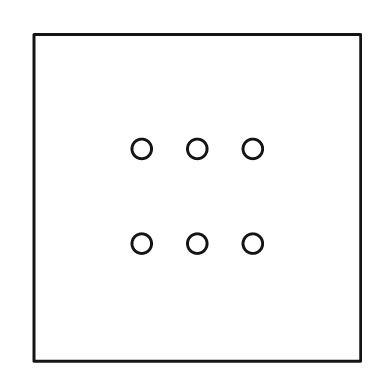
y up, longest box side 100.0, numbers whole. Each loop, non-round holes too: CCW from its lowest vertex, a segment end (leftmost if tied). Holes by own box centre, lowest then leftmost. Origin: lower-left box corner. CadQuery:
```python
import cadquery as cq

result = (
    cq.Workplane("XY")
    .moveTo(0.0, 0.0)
    .lineTo(100.0, 0.0)
    .lineTo(100.0, 100.0)
    .lineTo(0.0, 100.0)
    .close()
    .moveTo(33.0, 36.0)
    .circle(3.0)
    .moveTo(50.0, 36.0)
    .circle(3.0)
    .moveTo(67.0, 36.0)
    .circle(3.0)
    .moveTo(33.0, 65.0)
    .circle(3.0)
    .moveTo(50.0, 65.0)
    .circle(3.0)
    .moveTo(67.0, 65.0)
    .circle(3.0)
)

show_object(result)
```